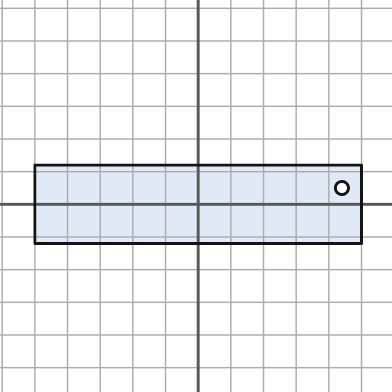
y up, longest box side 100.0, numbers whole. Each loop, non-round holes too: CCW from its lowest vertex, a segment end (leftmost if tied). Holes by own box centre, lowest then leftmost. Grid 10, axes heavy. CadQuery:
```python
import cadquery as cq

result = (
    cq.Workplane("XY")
    .moveTo(-50.0, -12.0)
    .lineTo(50.0, -12.0)
    .lineTo(50.0, 12.0)
    .lineTo(-50.0, 12.0)
    .close()
    .moveTo(44.0, 5.0)
    .circle(2.0)
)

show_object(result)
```